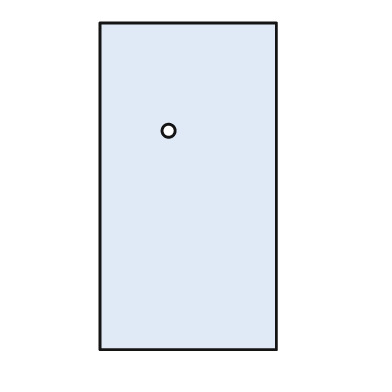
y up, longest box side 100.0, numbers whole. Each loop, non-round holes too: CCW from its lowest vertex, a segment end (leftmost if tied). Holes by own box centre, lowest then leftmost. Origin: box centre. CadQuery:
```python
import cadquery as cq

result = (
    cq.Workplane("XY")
    .moveTo(-27.0, -50.0)
    .lineTo(27.0, -50.0)
    .lineTo(27.0, 50.0)
    .lineTo(-27.0, 50.0)
    .close()
    .moveTo(-6.0, 17.0)
    .circle(2.0)
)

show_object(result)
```